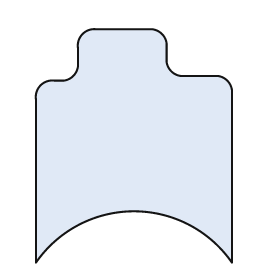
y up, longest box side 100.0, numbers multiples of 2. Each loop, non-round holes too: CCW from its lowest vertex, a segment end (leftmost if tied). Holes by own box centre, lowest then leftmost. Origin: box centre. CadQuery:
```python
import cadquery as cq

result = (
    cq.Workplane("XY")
    .moveTo(-42.0, -50.0)
    .threePointArc((0.0, -28.0), (42.0, -50.0))
    .lineTo(42.0, 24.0)
    .threePointArc((40.0, 28.0), (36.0, 30.0))
    .lineTo(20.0, 30.0)
    .threePointArc((16.0, 32.0), (14.0, 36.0))
    .lineTo(14.0, 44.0)
    .threePointArc((12.0, 48.0), (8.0, 50.0))
    .lineTo(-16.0, 50.0)
    .threePointArc((-22.0, 48.0), (-24.0, 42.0))
    .lineTo(-24.0, 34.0)
    .threePointArc((-26.0, 30.0), (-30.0, 28.0))
    .lineTo(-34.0, 28.0)
    .threePointArc((-40.0, 26.0), (-42.0, 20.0))
    .close()
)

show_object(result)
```